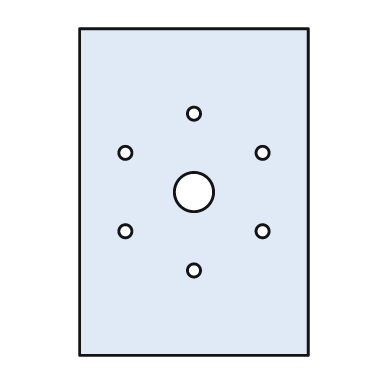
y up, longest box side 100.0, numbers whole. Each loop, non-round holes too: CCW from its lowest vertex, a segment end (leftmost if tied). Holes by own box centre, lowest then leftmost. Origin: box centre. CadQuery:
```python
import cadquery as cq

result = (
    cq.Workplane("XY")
    .moveTo(-35.0, -50.0)
    .lineTo(35.0, -50.0)
    .lineTo(35.0, 50.0)
    .lineTo(-35.0, 50.0)
    .close()
    .moveTo(0.0, -24.0)
    .circle(2.0)
    .moveTo(-21.0, -12.0)
    .circle(2.0)
    .moveTo(21.0, -12.0)
    .circle(2.0)
    .moveTo(0.0, 0.0)
    .circle(6.0)
    .moveTo(-21.0, 12.0)
    .circle(2.0)
    .moveTo(21.0, 12.0)
    .circle(2.0)
    .moveTo(0.0, 24.0)
    .circle(2.0)
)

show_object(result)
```